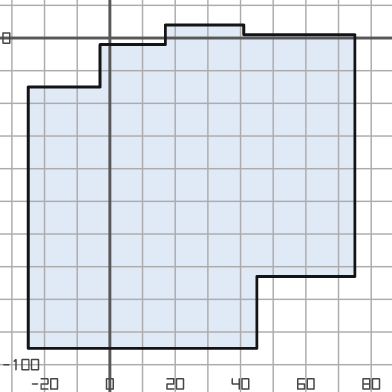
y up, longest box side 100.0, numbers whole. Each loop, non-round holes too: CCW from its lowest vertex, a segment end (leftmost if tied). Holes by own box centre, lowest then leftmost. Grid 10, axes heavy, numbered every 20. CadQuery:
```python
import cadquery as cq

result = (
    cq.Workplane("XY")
    .moveTo(-25.0, -95.0)
    .lineTo(45.0, -95.0)
    .lineTo(45.0, -73.0)
    .lineTo(75.0, -73.0)
    .lineTo(75.0, 1.0)
    .lineTo(41.0, 1.0)
    .lineTo(41.0, 4.0)
    .lineTo(17.0, 4.0)
    .lineTo(17.0, -2.0)
    .lineTo(-3.0, -2.0)
    .lineTo(-3.0, -15.0)
    .lineTo(-25.0, -15.0)
    .close()
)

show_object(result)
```